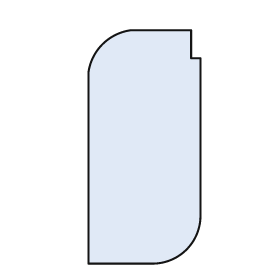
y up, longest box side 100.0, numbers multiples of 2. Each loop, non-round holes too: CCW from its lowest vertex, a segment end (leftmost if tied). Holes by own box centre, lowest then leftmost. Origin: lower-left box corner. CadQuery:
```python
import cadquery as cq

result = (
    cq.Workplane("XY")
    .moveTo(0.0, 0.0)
    .lineTo(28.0, 0.0)
    .threePointArc((42.0, 6.0), (48.0, 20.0))
    .lineTo(48.0, 88.0)
    .lineTo(44.0, 88.0)
    .lineTo(44.0, 100.0)
    .lineTo(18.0, 100.0)
    .threePointArc((6.0, 94.0), (0.0, 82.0))
    .close()
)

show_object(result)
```